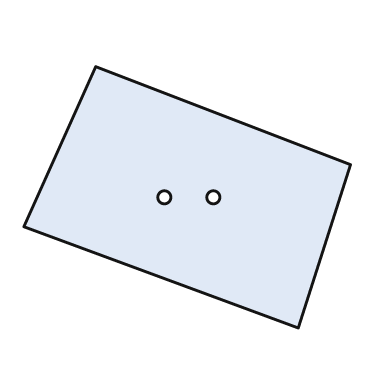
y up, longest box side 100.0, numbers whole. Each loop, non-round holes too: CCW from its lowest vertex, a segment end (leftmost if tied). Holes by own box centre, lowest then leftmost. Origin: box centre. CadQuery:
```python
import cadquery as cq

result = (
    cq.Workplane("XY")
    .moveTo(34.0, -40.0)
    .lineTo(50.0, 10.0)
    .lineTo(-28.0, 40.0)
    .lineTo(-50.0, -9.0)
    .close()
    .moveTo(-7.0, 0.0)
    .circle(2.0)
    .moveTo(8.0, 0.0)
    .circle(2.0)
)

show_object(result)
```